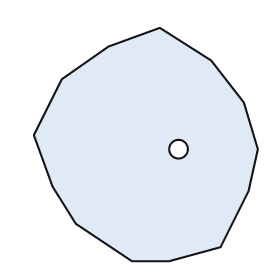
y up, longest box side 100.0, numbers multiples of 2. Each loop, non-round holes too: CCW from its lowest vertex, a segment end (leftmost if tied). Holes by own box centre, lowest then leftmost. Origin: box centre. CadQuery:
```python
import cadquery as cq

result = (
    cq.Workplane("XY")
    .moveTo(-6.0, -50.0)
    .lineTo(10.0, -50.0)
    .lineTo(32.0, -44.0)
    .lineTo(44.0, -20.0)
    .lineTo(48.0, -2.0)
    .lineTo(42.0, 18.0)
    .lineTo(28.0, 36.0)
    .lineTo(6.0, 50.0)
    .lineTo(-16.0, 42.0)
    .lineTo(-36.0, 28.0)
    .lineTo(-48.0, 4.0)
    .lineTo(-40.0, -18.0)
    .lineTo(-30.0, -34.0)
    .close()
    .moveTo(14.0, -2.0)
    .circle(4.0)
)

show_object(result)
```